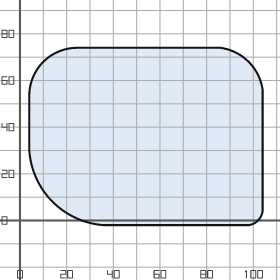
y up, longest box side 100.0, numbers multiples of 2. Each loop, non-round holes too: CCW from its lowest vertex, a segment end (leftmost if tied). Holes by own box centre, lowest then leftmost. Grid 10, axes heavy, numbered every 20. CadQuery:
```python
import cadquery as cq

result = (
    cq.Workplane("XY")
    .moveTo(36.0, -2.0)
    .lineTo(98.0, -2.0)
    .threePointArc((102.0, 0.0), (104.0, 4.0))
    .lineTo(104.0, 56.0)
    .threePointArc((98.0, 68.0), (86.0, 74.0))
    .lineTo(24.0, 74.0)
    .threePointArc((10.0, 68.0), (4.0, 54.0))
    .lineTo(4.0, 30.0)
    .threePointArc((14.0, 8.0), (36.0, -2.0))
    .close()
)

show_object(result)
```